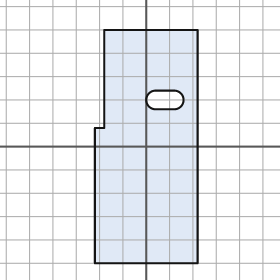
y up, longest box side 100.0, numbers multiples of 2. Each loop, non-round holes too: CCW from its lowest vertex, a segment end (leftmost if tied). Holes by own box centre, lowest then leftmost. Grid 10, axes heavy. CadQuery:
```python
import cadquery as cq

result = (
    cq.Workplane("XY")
    .moveTo(-22.0, -50.0)
    .lineTo(22.0, -50.0)
    .lineTo(22.0, 50.0)
    .lineTo(-18.0, 50.0)
    .lineTo(-18.0, 8.0)
    .lineTo(-22.0, 8.0)
    .close()
    .moveTo(4.0, 16.0)
    .lineTo(12.0, 16.0)
    .threePointArc((16.0, 20.0), (12.0, 24.0))
    .lineTo(4.0, 24.0)
    .threePointArc((0.0, 20.0), (4.0, 16.0))
    .close()
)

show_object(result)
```